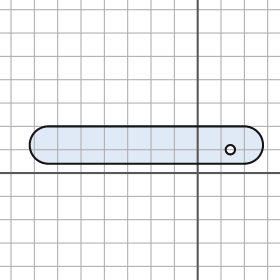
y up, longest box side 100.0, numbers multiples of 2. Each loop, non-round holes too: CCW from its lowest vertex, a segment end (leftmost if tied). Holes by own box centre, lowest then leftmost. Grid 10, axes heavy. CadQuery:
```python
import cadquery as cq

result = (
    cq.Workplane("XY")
    .moveTo(-64.0, 4.0)
    .lineTo(20.0, 4.0)
    .threePointArc((28.0, 12.0), (20.0, 20.0))
    .lineTo(-64.0, 20.0)
    .threePointArc((-72.0, 12.0), (-64.0, 4.0))
    .close()
    .moveTo(14.0, 10.0)
    .circle(2.0)
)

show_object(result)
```